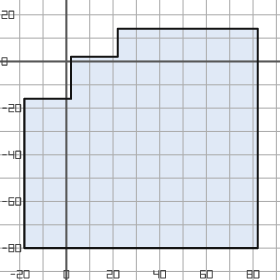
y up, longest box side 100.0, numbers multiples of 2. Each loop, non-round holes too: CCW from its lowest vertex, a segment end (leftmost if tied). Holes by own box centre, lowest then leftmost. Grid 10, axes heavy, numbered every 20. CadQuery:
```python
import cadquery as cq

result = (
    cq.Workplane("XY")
    .moveTo(-18.0, -80.0)
    .lineTo(82.0, -80.0)
    .lineTo(82.0, 14.0)
    .lineTo(22.0, 14.0)
    .lineTo(22.0, 2.0)
    .lineTo(2.0, 2.0)
    .lineTo(2.0, -16.0)
    .lineTo(-18.0, -16.0)
    .close()
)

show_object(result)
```